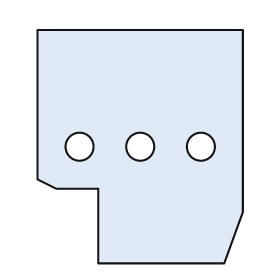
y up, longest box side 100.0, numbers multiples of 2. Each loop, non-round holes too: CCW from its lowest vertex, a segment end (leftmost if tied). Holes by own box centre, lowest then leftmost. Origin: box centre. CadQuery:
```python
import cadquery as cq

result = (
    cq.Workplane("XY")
    .moveTo(-18.0, -50.0)
    .lineTo(36.0, -50.0)
    .lineTo(44.0, -28.0)
    .lineTo(44.0, 50.0)
    .lineTo(-44.0, 50.0)
    .lineTo(-44.0, -14.0)
    .lineTo(-36.0, -18.0)
    .lineTo(-18.0, -18.0)
    .close()
    .moveTo(-26.0, 0.0)
    .circle(6.0)
    .moveTo(0.0, 0.0)
    .circle(6.0)
    .moveTo(26.0, 0.0)
    .circle(6.0)
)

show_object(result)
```